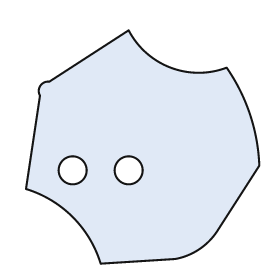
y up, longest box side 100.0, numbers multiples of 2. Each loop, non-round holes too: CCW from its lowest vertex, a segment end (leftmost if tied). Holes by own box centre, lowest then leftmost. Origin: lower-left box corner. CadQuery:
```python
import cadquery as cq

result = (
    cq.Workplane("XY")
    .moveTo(32.0, 0.0)
    .lineTo(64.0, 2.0)
    .threePointArc((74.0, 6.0), (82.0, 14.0))
    .lineTo(100.0, 42.0)
    .threePointArc((96.0, 64.0), (86.0, 84.0))
    .threePointArc((62.0, 84.0), (44.0, 100.0))
    .lineTo(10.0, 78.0)
    .threePointArc((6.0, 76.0), (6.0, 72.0))
    .lineTo(0.0, 32.0)
    .threePointArc((20.0, 20.0), (32.0, 0.0))
    .close()
    .moveTo(20.0, 40.0)
    .circle(6.0)
    .moveTo(44.0, 40.0)
    .circle(6.0)
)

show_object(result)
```